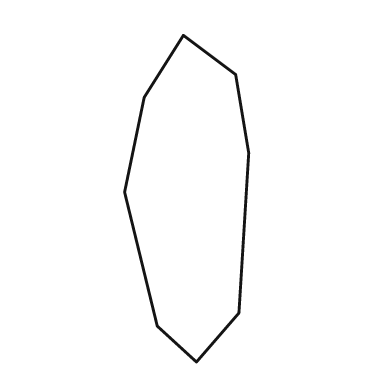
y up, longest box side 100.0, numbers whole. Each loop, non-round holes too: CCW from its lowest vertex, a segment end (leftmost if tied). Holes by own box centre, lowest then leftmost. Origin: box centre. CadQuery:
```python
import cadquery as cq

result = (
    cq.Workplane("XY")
    .moveTo(3.0, -50.0)
    .lineTo(16.0, -35.0)
    .lineTo(19.0, 14.0)
    .lineTo(15.0, 38.0)
    .lineTo(-1.0, 50.0)
    .lineTo(-13.0, 31.0)
    .lineTo(-19.0, 2.0)
    .lineTo(-9.0, -39.0)
    .close()
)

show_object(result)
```